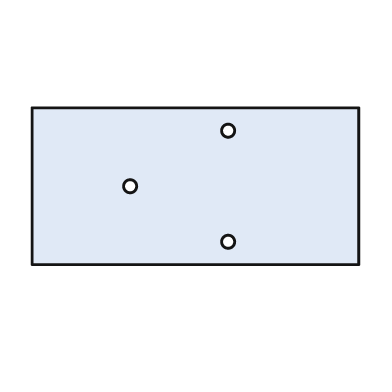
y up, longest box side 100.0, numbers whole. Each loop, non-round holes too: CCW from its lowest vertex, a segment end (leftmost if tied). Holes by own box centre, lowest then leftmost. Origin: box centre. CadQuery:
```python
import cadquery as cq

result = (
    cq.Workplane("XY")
    .moveTo(-50.0, -24.0)
    .lineTo(50.0, -24.0)
    .lineTo(50.0, 24.0)
    .lineTo(-50.0, 24.0)
    .close()
    .moveTo(10.0, -17.0)
    .circle(2.0)
    .moveTo(-20.0, 0.0)
    .circle(2.0)
    .moveTo(10.0, 17.0)
    .circle(2.0)
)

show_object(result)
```